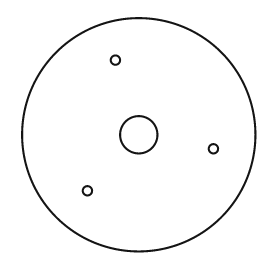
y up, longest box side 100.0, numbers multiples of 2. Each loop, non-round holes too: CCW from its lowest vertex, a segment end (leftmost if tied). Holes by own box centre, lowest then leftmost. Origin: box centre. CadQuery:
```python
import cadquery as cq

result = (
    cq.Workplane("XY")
    .moveTo(0.0, 0.0)
    .circle(50.0)
    .moveTo(-22.0, -24.0)
    .circle(2.0)
    .moveTo(32.0, -6.0)
    .circle(2.0)
    .moveTo(0.0, 0.0)
    .circle(8.0)
    .moveTo(-10.0, 32.0)
    .circle(2.0)
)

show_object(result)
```